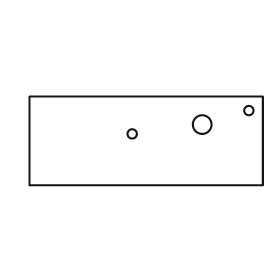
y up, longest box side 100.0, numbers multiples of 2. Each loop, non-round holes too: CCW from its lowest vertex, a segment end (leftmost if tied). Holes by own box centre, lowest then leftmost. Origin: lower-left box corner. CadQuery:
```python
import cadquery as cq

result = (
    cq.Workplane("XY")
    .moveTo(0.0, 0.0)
    .lineTo(100.0, 0.0)
    .lineTo(100.0, 38.0)
    .lineTo(0.0, 38.0)
    .close()
    .moveTo(44.0, 22.0)
    .circle(2.0)
    .moveTo(74.0, 26.0)
    .circle(4.0)
    .moveTo(94.0, 32.0)
    .circle(2.0)
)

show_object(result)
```